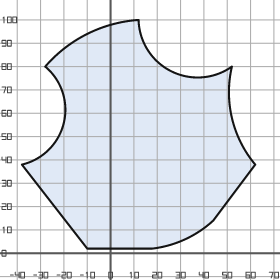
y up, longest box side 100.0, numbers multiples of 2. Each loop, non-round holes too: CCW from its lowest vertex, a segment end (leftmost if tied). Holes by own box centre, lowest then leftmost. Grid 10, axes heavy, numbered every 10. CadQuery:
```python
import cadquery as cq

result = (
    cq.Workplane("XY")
    .moveTo(-10.0, 2.0)
    .lineTo(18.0, 2.0)
    .threePointArc((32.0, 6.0), (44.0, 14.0))
    .lineTo(62.0, 38.0)
    .threePointArc((52.0, 58.0), (52.0, 80.0))
    .threePointArc((26.0, 78.0), (12.0, 100.0))
    .threePointArc((-10.0, 94.0), (-28.0, 80.0))
    .threePointArc((-20.0, 56.0), (-38.0, 38.0))
    .close()
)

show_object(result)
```